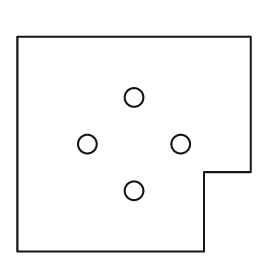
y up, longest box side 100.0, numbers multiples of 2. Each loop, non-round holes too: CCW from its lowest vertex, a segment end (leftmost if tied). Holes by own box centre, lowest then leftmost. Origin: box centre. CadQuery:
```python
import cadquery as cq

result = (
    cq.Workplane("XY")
    .moveTo(-50.0, -46.0)
    .lineTo(30.0, -46.0)
    .lineTo(30.0, -12.0)
    .lineTo(50.0, -12.0)
    .lineTo(50.0, 46.0)
    .lineTo(-50.0, 46.0)
    .close()
    .moveTo(0.0, -20.0)
    .circle(4.0)
    .moveTo(-20.0, 0.0)
    .circle(4.0)
    .moveTo(20.0, 0.0)
    .circle(4.0)
    .moveTo(0.0, 20.0)
    .circle(4.0)
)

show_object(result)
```